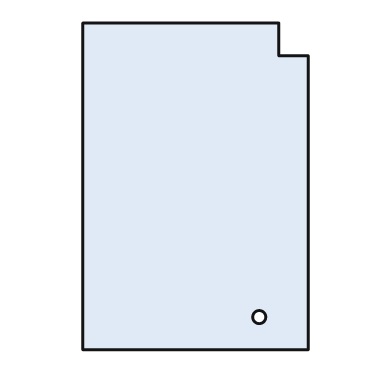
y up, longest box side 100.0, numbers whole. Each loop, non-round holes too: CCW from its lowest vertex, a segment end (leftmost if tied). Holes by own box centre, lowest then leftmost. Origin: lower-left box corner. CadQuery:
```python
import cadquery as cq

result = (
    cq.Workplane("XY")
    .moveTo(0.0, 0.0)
    .lineTo(69.0, 0.0)
    .lineTo(69.0, 90.0)
    .lineTo(60.0, 90.0)
    .lineTo(60.0, 100.0)
    .lineTo(0.0, 100.0)
    .close()
    .moveTo(54.0, 10.0)
    .circle(2.0)
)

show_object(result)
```